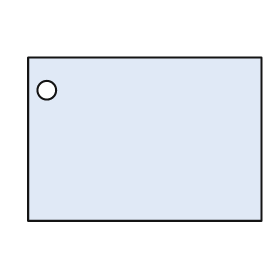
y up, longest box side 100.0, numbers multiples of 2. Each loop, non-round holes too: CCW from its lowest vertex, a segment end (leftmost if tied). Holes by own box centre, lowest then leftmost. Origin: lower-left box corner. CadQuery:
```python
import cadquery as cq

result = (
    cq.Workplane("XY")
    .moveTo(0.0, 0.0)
    .lineTo(100.0, 0.0)
    .lineTo(100.0, 70.0)
    .lineTo(0.0, 70.0)
    .close()
    .moveTo(8.0, 56.0)
    .circle(4.0)
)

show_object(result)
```